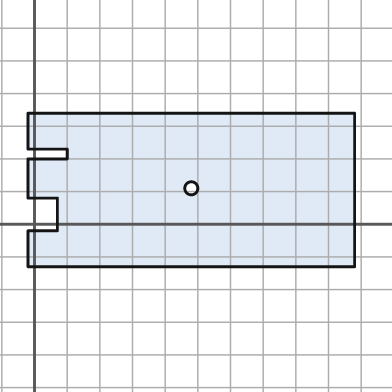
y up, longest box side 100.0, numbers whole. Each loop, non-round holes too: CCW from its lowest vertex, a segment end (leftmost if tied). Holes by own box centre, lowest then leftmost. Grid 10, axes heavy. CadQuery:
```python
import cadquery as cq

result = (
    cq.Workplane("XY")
    .moveTo(-2.0, -13.0)
    .lineTo(98.0, -13.0)
    .lineTo(98.0, 34.0)
    .lineTo(-2.0, 34.0)
    .lineTo(-2.0, 23.0)
    .lineTo(10.0, 23.0)
    .lineTo(10.0, 20.0)
    .lineTo(-2.0, 20.0)
    .lineTo(-2.0, 8.0)
    .lineTo(7.0, 8.0)
    .lineTo(7.0, -2.0)
    .lineTo(-2.0, -2.0)
    .close()
    .moveTo(48.0, 11.0)
    .circle(2.0)
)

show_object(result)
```